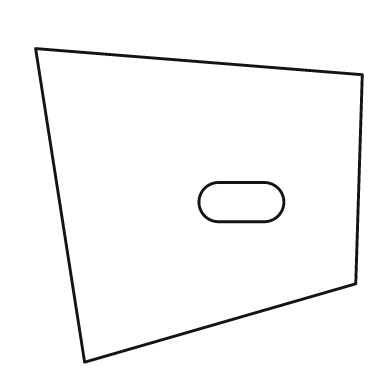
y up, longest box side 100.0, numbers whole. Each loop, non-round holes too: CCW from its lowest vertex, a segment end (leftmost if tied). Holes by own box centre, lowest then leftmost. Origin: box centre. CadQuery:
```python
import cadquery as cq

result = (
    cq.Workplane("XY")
    .moveTo(-35.0, -48.0)
    .lineTo(48.0, -24.0)
    .lineTo(50.0, 40.0)
    .lineTo(-50.0, 48.0)
    .close()
    .moveTo(6.0, -5.0)
    .lineTo(20.0, -5.0)
    .threePointArc((26.0, 1.0), (20.0, 7.0))
    .lineTo(6.0, 7.0)
    .threePointArc((0.0, 1.0), (6.0, -5.0))
    .close()
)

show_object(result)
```